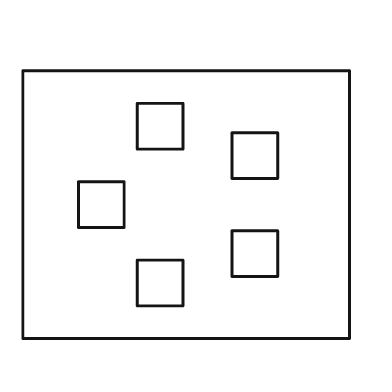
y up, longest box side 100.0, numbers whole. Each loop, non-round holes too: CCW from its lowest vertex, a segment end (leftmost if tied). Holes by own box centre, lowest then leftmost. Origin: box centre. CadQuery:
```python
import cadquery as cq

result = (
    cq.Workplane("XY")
    .moveTo(-50.0, -41.0)
    .lineTo(50.0, -41.0)
    .lineTo(50.0, 41.0)
    .lineTo(-50.0, 41.0)
    .close()
    .moveTo(-15.0, -31.0)
    .lineTo(-1.0, -31.0)
    .lineTo(-1.0, -17.0)
    .lineTo(-15.0, -17.0)
    .close()
    .moveTo(14.0, -22.0)
    .lineTo(28.0, -22.0)
    .lineTo(28.0, -8.0)
    .lineTo(14.0, -8.0)
    .close()
    .moveTo(-33.0, -7.0)
    .lineTo(-19.0, -7.0)
    .lineTo(-19.0, 7.0)
    .lineTo(-33.0, 7.0)
    .close()
    .moveTo(14.0, 8.0)
    .lineTo(28.0, 8.0)
    .lineTo(28.0, 22.0)
    .lineTo(14.0, 22.0)
    .close()
    .moveTo(-15.0, 17.0)
    .lineTo(-1.0, 17.0)
    .lineTo(-1.0, 31.0)
    .lineTo(-15.0, 31.0)
    .close()
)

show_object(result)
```